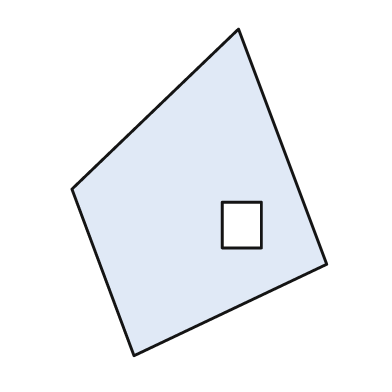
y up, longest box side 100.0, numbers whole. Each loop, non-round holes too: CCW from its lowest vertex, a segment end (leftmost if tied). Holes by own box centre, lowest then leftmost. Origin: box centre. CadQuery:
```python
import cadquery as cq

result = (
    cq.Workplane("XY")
    .moveTo(-20.0, -50.0)
    .lineTo(39.0, -22.0)
    .lineTo(12.0, 50.0)
    .lineTo(-39.0, 1.0)
    .close()
    .moveTo(7.0, -17.0)
    .lineTo(19.0, -17.0)
    .lineTo(19.0, -3.0)
    .lineTo(7.0, -3.0)
    .close()
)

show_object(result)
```